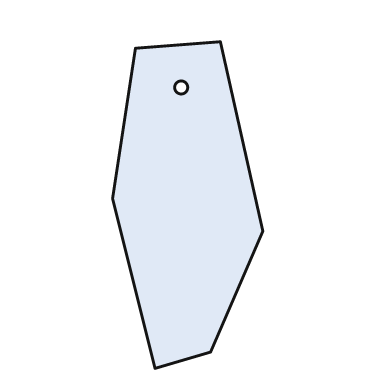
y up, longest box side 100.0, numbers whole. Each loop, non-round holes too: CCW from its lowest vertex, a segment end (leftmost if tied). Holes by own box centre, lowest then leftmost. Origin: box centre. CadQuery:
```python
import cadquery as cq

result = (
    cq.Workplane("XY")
    .moveTo(-10.0, -50.0)
    .lineTo(7.0, -45.0)
    .lineTo(23.0, -8.0)
    .lineTo(10.0, 50.0)
    .lineTo(-16.0, 48.0)
    .lineTo(-23.0, 2.0)
    .close()
    .moveTo(-2.0, 36.0)
    .circle(2.0)
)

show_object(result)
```